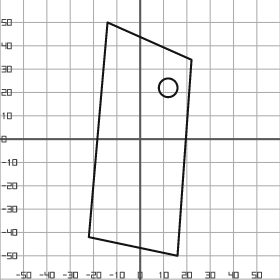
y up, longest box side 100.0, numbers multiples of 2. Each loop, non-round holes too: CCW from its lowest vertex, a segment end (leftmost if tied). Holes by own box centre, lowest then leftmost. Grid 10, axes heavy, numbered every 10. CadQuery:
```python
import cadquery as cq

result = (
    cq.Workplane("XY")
    .moveTo(16.0, -50.0)
    .lineTo(22.0, 34.0)
    .lineTo(-14.0, 50.0)
    .lineTo(-22.0, -42.0)
    .close()
    .moveTo(12.0, 22.0)
    .circle(4.0)
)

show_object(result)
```